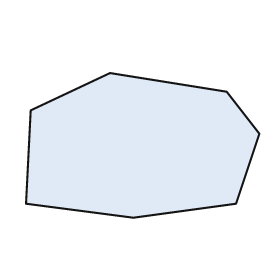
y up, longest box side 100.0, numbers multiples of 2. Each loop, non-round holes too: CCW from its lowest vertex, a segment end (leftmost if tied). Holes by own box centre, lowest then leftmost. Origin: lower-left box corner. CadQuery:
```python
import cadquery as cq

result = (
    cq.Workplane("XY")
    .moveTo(46.0, 0.0)
    .lineTo(90.0, 6.0)
    .lineTo(100.0, 36.0)
    .lineTo(86.0, 54.0)
    .lineTo(36.0, 62.0)
    .lineTo(2.0, 46.0)
    .lineTo(0.0, 6.0)
    .close()
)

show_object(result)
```